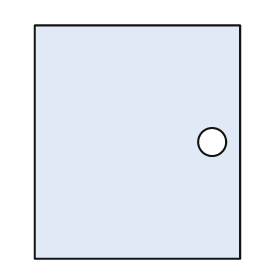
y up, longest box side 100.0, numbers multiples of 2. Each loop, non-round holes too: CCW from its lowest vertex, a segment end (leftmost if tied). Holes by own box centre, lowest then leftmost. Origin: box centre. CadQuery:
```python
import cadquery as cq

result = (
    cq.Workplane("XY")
    .moveTo(-44.0, -50.0)
    .lineTo(44.0, -50.0)
    .lineTo(44.0, 50.0)
    .lineTo(-44.0, 50.0)
    .close()
    .moveTo(32.0, 0.0)
    .circle(6.0)
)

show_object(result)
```